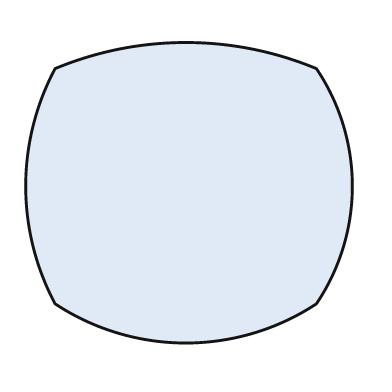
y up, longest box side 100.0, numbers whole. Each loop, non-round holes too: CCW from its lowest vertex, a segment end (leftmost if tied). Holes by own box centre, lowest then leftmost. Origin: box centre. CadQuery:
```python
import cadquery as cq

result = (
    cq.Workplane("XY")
    .moveTo(-41.0, -34.0)
    .threePointArc((-1.0, -46.0), (39.0, -34.0))
    .threePointArc((50.0, 2.0), (39.0, 38.0))
    .threePointArc((-1.0, 46.0), (-41.0, 38.0))
    .threePointArc((-50.0, 2.0), (-41.0, -34.0))
    .close()
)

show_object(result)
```